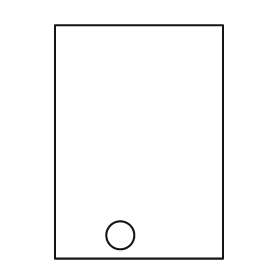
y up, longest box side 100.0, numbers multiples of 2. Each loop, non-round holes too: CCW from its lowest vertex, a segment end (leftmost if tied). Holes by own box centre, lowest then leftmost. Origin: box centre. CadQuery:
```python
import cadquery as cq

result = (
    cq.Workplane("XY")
    .moveTo(-36.0, -50.0)
    .lineTo(36.0, -50.0)
    .lineTo(36.0, 50.0)
    .lineTo(-36.0, 50.0)
    .close()
    .moveTo(-8.0, -40.0)
    .circle(6.0)
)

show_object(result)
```